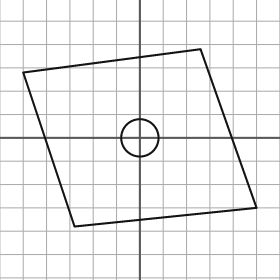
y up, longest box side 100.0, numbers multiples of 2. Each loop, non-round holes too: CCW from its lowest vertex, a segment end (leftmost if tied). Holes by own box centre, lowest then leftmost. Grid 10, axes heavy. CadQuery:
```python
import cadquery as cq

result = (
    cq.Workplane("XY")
    .moveTo(-28.0, -38.0)
    .lineTo(50.0, -30.0)
    .lineTo(26.0, 38.0)
    .lineTo(-50.0, 28.0)
    .close()
    .moveTo(0.0, 0.0)
    .circle(8.0)
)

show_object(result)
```